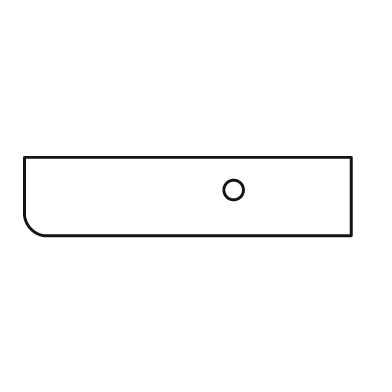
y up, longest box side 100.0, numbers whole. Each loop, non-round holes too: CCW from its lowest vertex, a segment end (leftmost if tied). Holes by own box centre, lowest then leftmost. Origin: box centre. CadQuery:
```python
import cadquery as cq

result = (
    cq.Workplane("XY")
    .moveTo(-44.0, -12.0)
    .lineTo(50.0, -12.0)
    .lineTo(50.0, 12.0)
    .lineTo(-50.0, 12.0)
    .lineTo(-50.0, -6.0)
    .threePointArc((-48.0, -10.0), (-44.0, -12.0))
    .close()
    .moveTo(14.0, 2.0)
    .circle(3.0)
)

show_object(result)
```